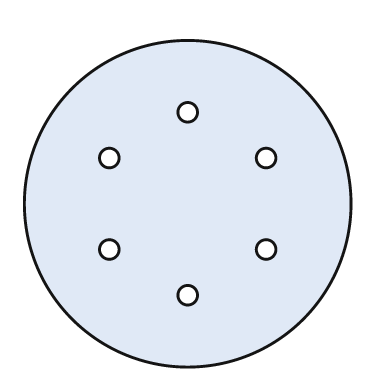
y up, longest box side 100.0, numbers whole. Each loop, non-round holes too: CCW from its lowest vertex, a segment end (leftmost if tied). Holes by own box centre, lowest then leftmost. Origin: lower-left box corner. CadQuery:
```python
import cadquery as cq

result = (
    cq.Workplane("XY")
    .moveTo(50.0, 50.0)
    .circle(50.0)
    .moveTo(50.0, 22.0)
    .circle(3.0)
    .moveTo(26.0, 36.0)
    .circle(3.0)
    .moveTo(74.0, 36.0)
    .circle(3.0)
    .moveTo(26.0, 64.0)
    .circle(3.0)
    .moveTo(74.0, 64.0)
    .circle(3.0)
    .moveTo(50.0, 78.0)
    .circle(3.0)
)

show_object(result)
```